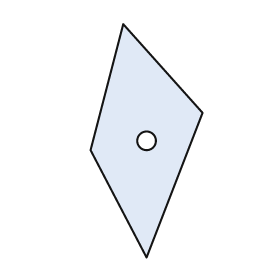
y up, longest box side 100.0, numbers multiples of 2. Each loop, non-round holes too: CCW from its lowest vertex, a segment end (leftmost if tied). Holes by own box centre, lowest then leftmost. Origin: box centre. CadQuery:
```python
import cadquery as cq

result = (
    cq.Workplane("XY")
    .moveTo(0.0, -50.0)
    .lineTo(24.0, 12.0)
    .lineTo(-10.0, 50.0)
    .lineTo(-24.0, -4.0)
    .close()
    .moveTo(0.0, 0.0)
    .circle(4.0)
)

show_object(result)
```